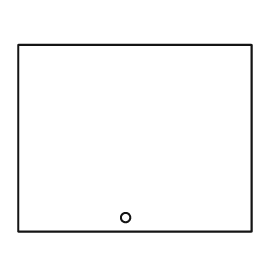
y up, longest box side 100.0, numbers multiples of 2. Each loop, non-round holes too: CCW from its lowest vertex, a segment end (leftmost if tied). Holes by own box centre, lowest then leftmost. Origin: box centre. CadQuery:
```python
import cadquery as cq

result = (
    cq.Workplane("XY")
    .moveTo(-50.0, -40.0)
    .lineTo(50.0, -40.0)
    .lineTo(50.0, 40.0)
    .lineTo(-50.0, 40.0)
    .close()
    .moveTo(-4.0, -34.0)
    .circle(2.0)
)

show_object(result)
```